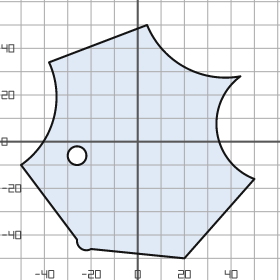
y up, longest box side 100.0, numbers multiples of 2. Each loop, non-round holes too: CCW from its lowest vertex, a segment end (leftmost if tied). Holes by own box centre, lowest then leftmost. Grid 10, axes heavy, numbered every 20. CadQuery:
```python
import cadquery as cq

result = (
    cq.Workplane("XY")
    .moveTo(20.0, -50.0)
    .lineTo(50.0, -16.0)
    .threePointArc((34.0, 4.0), (44.0, 28.0))
    .threePointArc((20.0, 32.0), (4.0, 50.0))
    .lineTo(-38.0, 34.0)
    .threePointArc((-36.0, 10.0), (-50.0, -10.0))
    .lineTo(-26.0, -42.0)
    .threePointArc((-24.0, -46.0), (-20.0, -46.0))
    .close()
    .moveTo(-26.0, -6.0)
    .circle(4.0)
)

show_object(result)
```